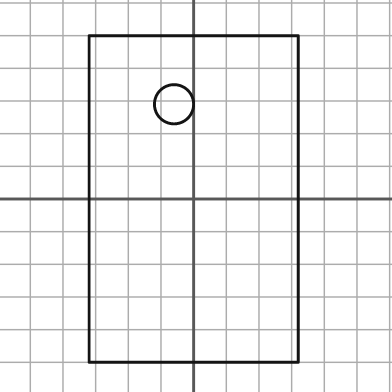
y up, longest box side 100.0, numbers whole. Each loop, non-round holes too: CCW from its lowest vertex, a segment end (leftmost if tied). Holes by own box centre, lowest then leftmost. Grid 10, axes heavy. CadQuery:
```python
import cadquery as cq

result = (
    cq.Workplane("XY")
    .moveTo(-32.0, -50.0)
    .lineTo(32.0, -50.0)
    .lineTo(32.0, 50.0)
    .lineTo(-32.0, 50.0)
    .close()
    .moveTo(-6.0, 29.0)
    .circle(6.0)
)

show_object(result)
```